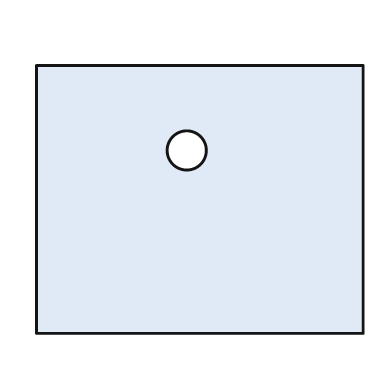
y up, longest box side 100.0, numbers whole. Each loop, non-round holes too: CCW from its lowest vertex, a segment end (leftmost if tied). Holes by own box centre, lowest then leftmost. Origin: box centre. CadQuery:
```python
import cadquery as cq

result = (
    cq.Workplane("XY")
    .moveTo(-50.0, -41.0)
    .lineTo(50.0, -41.0)
    .lineTo(50.0, 41.0)
    .lineTo(-50.0, 41.0)
    .close()
    .moveTo(-4.0, 15.0)
    .circle(6.0)
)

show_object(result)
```